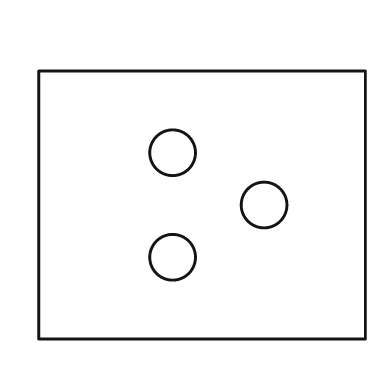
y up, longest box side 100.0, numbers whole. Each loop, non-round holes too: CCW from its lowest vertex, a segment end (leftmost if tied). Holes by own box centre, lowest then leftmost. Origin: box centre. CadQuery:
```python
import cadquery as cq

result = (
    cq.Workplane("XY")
    .moveTo(-50.0, -41.0)
    .lineTo(50.0, -41.0)
    .lineTo(50.0, 41.0)
    .lineTo(-50.0, 41.0)
    .close()
    .moveTo(-9.0, -16.0)
    .circle(7.0)
    .moveTo(19.0, 0.0)
    .circle(7.0)
    .moveTo(-9.0, 16.0)
    .circle(7.0)
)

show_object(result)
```